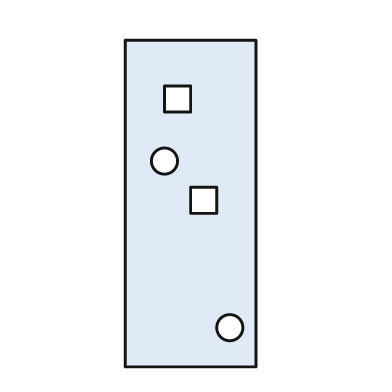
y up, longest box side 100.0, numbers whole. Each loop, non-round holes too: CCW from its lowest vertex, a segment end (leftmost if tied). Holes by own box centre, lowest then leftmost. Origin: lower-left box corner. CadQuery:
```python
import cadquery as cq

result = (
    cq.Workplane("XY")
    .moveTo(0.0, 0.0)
    .lineTo(40.0, 0.0)
    .lineTo(40.0, 100.0)
    .lineTo(0.0, 100.0)
    .close()
    .moveTo(32.0, 12.0)
    .circle(4.0)
    .moveTo(20.0, 47.0)
    .lineTo(28.0, 47.0)
    .lineTo(28.0, 55.0)
    .lineTo(20.0, 55.0)
    .close()
    .moveTo(12.0, 63.0)
    .circle(4.0)
    .moveTo(12.0, 78.0)
    .lineTo(20.0, 78.0)
    .lineTo(20.0, 86.0)
    .lineTo(12.0, 86.0)
    .close()
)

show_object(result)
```